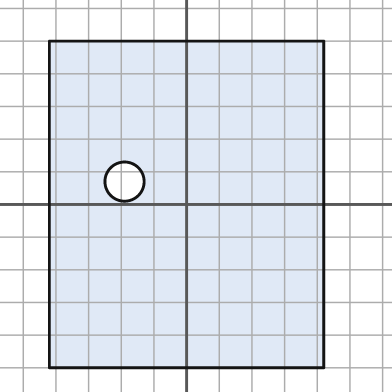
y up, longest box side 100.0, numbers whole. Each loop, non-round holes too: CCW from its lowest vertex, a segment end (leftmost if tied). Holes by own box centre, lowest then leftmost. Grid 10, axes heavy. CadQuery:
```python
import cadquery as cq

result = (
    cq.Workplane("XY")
    .moveTo(-42.0, -50.0)
    .lineTo(42.0, -50.0)
    .lineTo(42.0, 50.0)
    .lineTo(-42.0, 50.0)
    .close()
    .moveTo(-19.0, 7.0)
    .circle(6.0)
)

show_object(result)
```